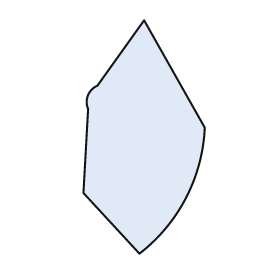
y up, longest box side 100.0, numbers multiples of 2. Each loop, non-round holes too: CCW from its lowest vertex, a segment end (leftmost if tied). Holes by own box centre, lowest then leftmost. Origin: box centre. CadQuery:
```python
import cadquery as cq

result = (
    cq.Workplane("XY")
    .moveTo(-2.0, -50.0)
    .threePointArc((18.0, -26.0), (26.0, 4.0))
    .lineTo(0.0, 50.0)
    .lineTo(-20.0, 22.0)
    .threePointArc((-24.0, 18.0), (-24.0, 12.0))
    .lineTo(-26.0, -24.0)
    .close()
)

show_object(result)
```